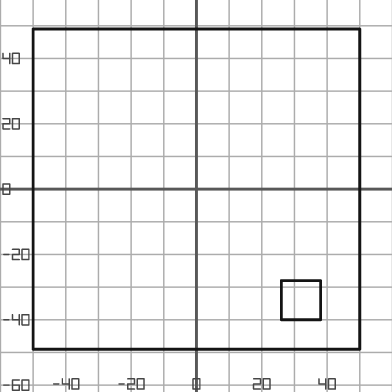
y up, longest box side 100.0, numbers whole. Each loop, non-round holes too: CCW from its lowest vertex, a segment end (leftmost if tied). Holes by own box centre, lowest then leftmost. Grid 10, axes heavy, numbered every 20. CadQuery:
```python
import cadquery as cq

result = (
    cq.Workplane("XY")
    .moveTo(-50.0, -49.0)
    .lineTo(50.0, -49.0)
    .lineTo(50.0, 49.0)
    .lineTo(-50.0, 49.0)
    .close()
    .moveTo(26.0, -40.0)
    .lineTo(38.0, -40.0)
    .lineTo(38.0, -28.0)
    .lineTo(26.0, -28.0)
    .close()
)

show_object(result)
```